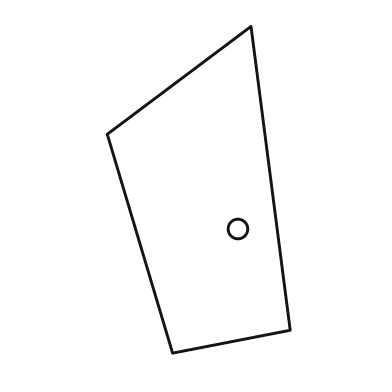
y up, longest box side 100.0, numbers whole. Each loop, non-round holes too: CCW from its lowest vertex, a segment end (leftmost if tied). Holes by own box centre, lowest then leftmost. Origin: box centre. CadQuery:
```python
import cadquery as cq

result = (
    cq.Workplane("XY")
    .moveTo(-8.0, -50.0)
    .lineTo(28.0, -43.0)
    .lineTo(16.0, 50.0)
    .lineTo(-28.0, 17.0)
    .close()
    .moveTo(12.0, -12.0)
    .circle(3.0)
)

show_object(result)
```